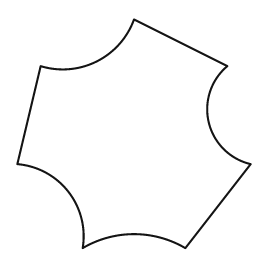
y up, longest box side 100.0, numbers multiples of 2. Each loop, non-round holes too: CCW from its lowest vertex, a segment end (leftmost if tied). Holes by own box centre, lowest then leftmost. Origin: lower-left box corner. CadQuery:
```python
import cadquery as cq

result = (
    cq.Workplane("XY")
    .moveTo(28.0, 0.0)
    .threePointArc((50.0, 6.0), (72.0, 0.0))
    .lineTo(100.0, 36.0)
    .threePointArc((82.0, 54.0), (90.0, 78.0))
    .lineTo(50.0, 98.0)
    .threePointArc((34.0, 80.0), (10.0, 78.0))
    .lineTo(0.0, 36.0)
    .threePointArc((22.0, 24.0), (28.0, 0.0))
    .close()
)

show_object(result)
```